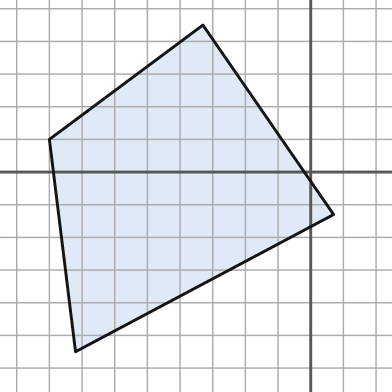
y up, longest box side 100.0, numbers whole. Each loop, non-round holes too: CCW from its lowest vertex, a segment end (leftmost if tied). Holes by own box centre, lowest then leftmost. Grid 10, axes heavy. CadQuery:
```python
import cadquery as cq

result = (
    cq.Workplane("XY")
    .moveTo(-72.0, -55.0)
    .lineTo(7.0, -13.0)
    .lineTo(-33.0, 45.0)
    .lineTo(-80.0, 10.0)
    .close()
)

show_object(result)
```